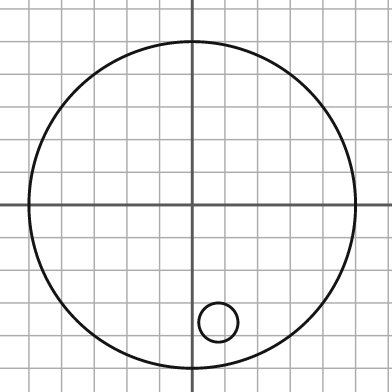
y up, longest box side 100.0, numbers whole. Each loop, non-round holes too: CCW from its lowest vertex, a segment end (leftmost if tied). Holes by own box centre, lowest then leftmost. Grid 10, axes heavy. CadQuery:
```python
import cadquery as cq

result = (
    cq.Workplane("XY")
    .moveTo(0.0, 0.0)
    .circle(50.0)
    .moveTo(8.0, -36.0)
    .circle(6.0)
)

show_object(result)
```